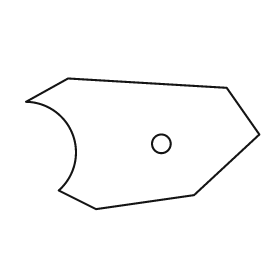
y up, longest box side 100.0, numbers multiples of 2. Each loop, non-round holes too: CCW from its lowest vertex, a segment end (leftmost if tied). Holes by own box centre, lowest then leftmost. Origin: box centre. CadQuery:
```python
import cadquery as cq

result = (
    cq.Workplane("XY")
    .moveTo(-20.0, -28.0)
    .lineTo(22.0, -22.0)
    .lineTo(50.0, 4.0)
    .lineTo(36.0, 24.0)
    .lineTo(-32.0, 28.0)
    .lineTo(-50.0, 18.0)
    .threePointArc((-30.0, 4.0), (-36.0, -20.0))
    .close()
    .moveTo(8.0, 0.0)
    .circle(4.0)
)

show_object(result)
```